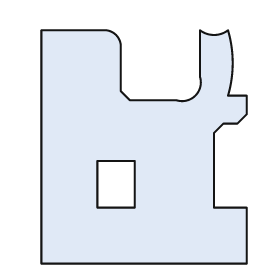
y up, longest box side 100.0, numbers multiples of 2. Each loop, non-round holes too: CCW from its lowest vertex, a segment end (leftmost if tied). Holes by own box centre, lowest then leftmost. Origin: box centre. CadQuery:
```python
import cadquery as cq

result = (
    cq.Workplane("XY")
    .moveTo(-44.0, -50.0)
    .lineTo(44.0, -50.0)
    .lineTo(44.0, -26.0)
    .lineTo(30.0, -26.0)
    .lineTo(30.0, 6.0)
    .lineTo(34.0, 10.0)
    .lineTo(40.0, 10.0)
    .lineTo(44.0, 14.0)
    .lineTo(44.0, 22.0)
    .lineTo(36.0, 22.0)
    .threePointArc((38.0, 36.0), (36.0, 50.0))
    .threePointArc((30.0, 48.0), (24.0, 50.0))
    .lineTo(24.0, 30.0)
    .threePointArc((22.0, 22.0), (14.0, 20.0))
    .lineTo(-6.0, 20.0)
    .lineTo(-10.0, 24.0)
    .lineTo(-10.0, 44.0)
    .threePointArc((-12.0, 48.0), (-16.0, 50.0))
    .lineTo(-44.0, 50.0)
    .close()
    .moveTo(-20.0, -26.0)
    .lineTo(-4.0, -26.0)
    .lineTo(-4.0, -6.0)
    .lineTo(-20.0, -6.0)
    .close()
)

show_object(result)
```